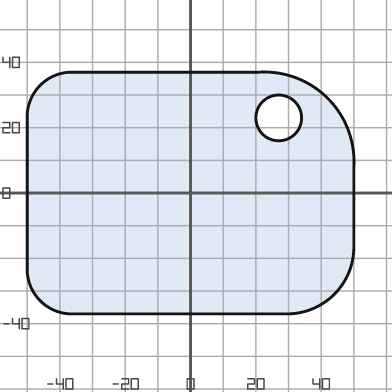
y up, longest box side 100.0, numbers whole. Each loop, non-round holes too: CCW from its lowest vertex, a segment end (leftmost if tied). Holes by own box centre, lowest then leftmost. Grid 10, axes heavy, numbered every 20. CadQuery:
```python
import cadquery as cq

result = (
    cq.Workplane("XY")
    .moveTo(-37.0, -37.0)
    .lineTo(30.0, -37.0)
    .threePointArc((44.0, -31.0), (50.0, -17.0))
    .lineTo(50.0, 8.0)
    .threePointArc((42.0, 29.0), (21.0, 37.0))
    .lineTo(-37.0, 37.0)
    .threePointArc((-46.0, 33.0), (-50.0, 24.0))
    .lineTo(-50.0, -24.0)
    .threePointArc((-46.0, -33.0), (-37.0, -37.0))
    .close()
    .moveTo(27.0, 23.0)
    .circle(7.0)
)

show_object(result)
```